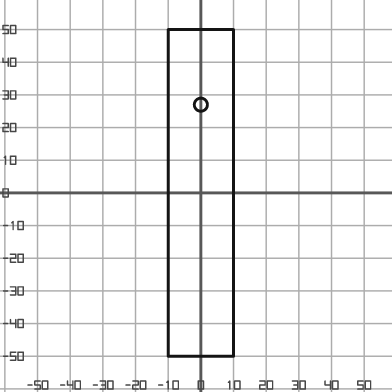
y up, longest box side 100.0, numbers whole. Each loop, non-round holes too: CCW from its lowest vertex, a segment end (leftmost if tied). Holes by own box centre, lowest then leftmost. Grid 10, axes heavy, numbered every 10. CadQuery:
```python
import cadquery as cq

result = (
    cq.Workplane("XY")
    .moveTo(-10.0, -50.0)
    .lineTo(10.0, -50.0)
    .lineTo(10.0, 50.0)
    .lineTo(-10.0, 50.0)
    .close()
    .moveTo(0.0, 27.0)
    .circle(2.0)
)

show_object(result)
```